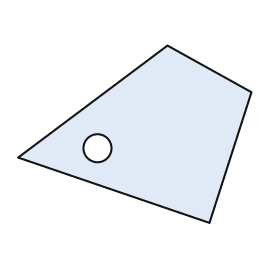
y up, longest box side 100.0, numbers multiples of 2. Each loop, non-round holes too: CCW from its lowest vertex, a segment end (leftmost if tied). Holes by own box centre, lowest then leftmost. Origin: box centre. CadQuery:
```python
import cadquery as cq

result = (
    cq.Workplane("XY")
    .moveTo(32.0, -38.0)
    .lineTo(50.0, 18.0)
    .lineTo(14.0, 38.0)
    .lineTo(-50.0, -10.0)
    .close()
    .moveTo(-16.0, -6.0)
    .circle(6.0)
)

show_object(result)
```